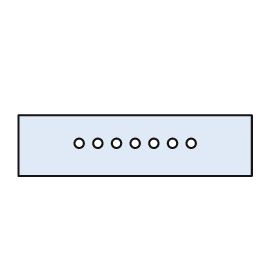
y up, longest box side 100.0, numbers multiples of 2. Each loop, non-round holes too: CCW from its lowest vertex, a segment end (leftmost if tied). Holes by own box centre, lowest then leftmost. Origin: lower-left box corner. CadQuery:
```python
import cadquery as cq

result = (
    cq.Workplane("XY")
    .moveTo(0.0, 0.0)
    .lineTo(100.0, 0.0)
    .lineTo(100.0, 26.0)
    .lineTo(0.0, 26.0)
    .close()
    .moveTo(26.0, 14.0)
    .circle(2.0)
    .moveTo(34.0, 14.0)
    .circle(2.0)
    .moveTo(42.0, 14.0)
    .circle(2.0)
    .moveTo(50.0, 14.0)
    .circle(2.0)
    .moveTo(58.0, 14.0)
    .circle(2.0)
    .moveTo(66.0, 14.0)
    .circle(2.0)
    .moveTo(74.0, 14.0)
    .circle(2.0)
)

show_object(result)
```